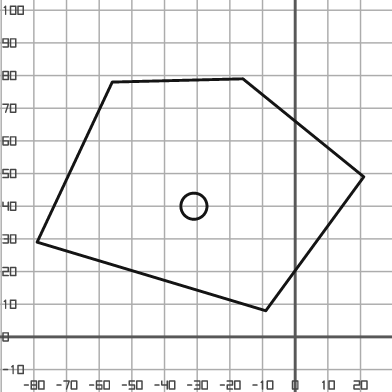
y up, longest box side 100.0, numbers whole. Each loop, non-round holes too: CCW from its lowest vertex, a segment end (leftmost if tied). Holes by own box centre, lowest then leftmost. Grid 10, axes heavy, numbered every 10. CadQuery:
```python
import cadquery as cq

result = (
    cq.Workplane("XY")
    .moveTo(-9.0, 8.0)
    .lineTo(21.0, 49.0)
    .lineTo(-16.0, 79.0)
    .lineTo(-56.0, 78.0)
    .lineTo(-79.0, 29.0)
    .close()
    .moveTo(-31.0, 40.0)
    .circle(4.0)
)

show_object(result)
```